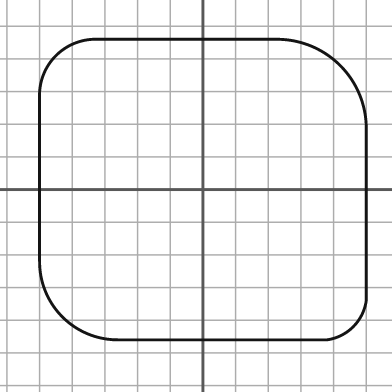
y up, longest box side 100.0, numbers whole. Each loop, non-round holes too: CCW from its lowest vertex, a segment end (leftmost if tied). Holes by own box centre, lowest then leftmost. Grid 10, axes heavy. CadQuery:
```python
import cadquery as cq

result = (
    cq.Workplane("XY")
    .moveTo(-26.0, -46.0)
    .lineTo(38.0, -46.0)
    .threePointArc((46.0, -42.0), (50.0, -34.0))
    .lineTo(50.0, 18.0)
    .threePointArc((42.0, 38.0), (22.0, 46.0))
    .lineTo(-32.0, 46.0)
    .threePointArc((-45.0, 41.0), (-50.0, 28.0))
    .lineTo(-50.0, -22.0)
    .threePointArc((-43.0, -39.0), (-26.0, -46.0))
    .close()
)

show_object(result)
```